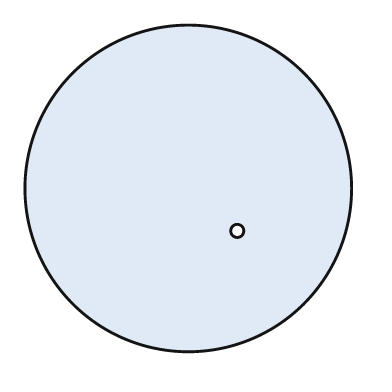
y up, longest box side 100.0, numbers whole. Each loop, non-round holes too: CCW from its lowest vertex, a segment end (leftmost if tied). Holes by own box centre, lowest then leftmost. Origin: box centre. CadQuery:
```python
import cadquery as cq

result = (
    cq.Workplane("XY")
    .moveTo(0.0, 0.0)
    .circle(50.0)
    .moveTo(15.0, -13.0)
    .circle(2.0)
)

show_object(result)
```